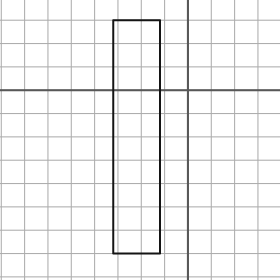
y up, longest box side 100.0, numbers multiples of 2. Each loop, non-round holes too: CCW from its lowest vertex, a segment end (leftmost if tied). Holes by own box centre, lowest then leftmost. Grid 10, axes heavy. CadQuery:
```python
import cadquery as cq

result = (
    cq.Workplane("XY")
    .moveTo(-32.0, -70.0)
    .lineTo(-12.0, -70.0)
    .lineTo(-12.0, 30.0)
    .lineTo(-32.0, 30.0)
    .close()
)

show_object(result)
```